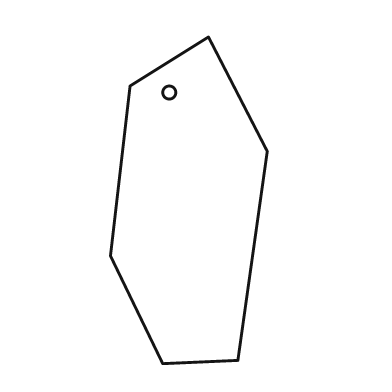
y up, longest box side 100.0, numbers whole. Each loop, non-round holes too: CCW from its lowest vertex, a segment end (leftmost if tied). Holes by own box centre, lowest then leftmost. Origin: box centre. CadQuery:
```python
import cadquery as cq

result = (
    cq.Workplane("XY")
    .moveTo(-8.0, -50.0)
    .lineTo(15.0, -49.0)
    .lineTo(24.0, 15.0)
    .lineTo(6.0, 50.0)
    .lineTo(-18.0, 35.0)
    .lineTo(-24.0, -17.0)
    .close()
    .moveTo(-6.0, 33.0)
    .circle(2.0)
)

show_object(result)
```